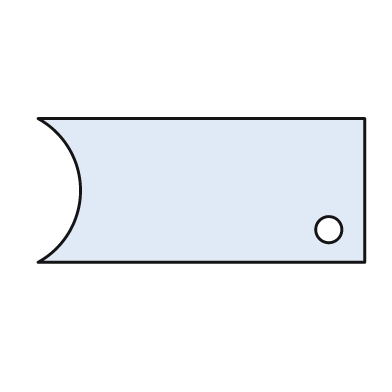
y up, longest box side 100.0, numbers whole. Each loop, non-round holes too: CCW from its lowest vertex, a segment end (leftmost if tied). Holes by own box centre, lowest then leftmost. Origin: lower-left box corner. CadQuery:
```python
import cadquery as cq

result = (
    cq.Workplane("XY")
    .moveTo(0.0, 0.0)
    .lineTo(100.0, 0.0)
    .lineTo(100.0, 44.0)
    .lineTo(0.0, 44.0)
    .threePointArc((13.0, 22.0), (0.0, 0.0))
    .close()
    .moveTo(89.0, 10.0)
    .circle(4.0)
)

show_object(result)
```